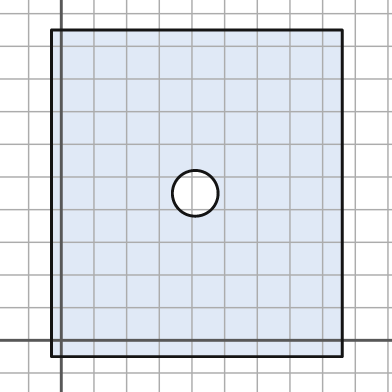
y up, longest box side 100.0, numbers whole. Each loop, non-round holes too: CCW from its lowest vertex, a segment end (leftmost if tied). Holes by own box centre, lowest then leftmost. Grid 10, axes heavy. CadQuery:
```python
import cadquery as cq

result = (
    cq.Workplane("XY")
    .moveTo(-3.0, -5.0)
    .lineTo(86.0, -5.0)
    .lineTo(86.0, 95.0)
    .lineTo(-3.0, 95.0)
    .close()
    .moveTo(41.0, 45.0)
    .circle(7.0)
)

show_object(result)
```